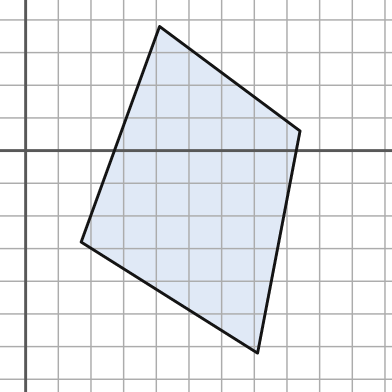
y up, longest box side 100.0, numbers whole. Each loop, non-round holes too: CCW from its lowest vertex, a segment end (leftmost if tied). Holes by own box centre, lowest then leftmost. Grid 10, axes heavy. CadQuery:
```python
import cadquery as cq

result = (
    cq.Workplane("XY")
    .moveTo(71.0, -62.0)
    .lineTo(84.0, 6.0)
    .lineTo(41.0, 38.0)
    .lineTo(17.0, -28.0)
    .close()
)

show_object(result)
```